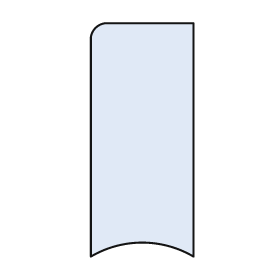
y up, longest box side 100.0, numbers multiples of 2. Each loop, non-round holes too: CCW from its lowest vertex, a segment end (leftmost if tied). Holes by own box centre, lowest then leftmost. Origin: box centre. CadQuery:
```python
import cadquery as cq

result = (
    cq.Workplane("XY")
    .moveTo(-22.0, -50.0)
    .threePointArc((0.0, -44.0), (22.0, -50.0))
    .lineTo(22.0, 50.0)
    .lineTo(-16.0, 50.0)
    .threePointArc((-20.0, 48.0), (-22.0, 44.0))
    .close()
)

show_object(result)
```